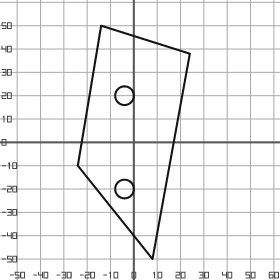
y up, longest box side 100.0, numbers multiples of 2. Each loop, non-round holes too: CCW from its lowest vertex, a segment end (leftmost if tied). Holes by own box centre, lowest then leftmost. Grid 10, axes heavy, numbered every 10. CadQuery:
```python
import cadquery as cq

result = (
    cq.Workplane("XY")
    .moveTo(8.0, -50.0)
    .lineTo(24.0, 38.0)
    .lineTo(-14.0, 50.0)
    .lineTo(-24.0, -10.0)
    .close()
    .moveTo(-4.0, -20.0)
    .circle(4.0)
    .moveTo(-4.0, 20.0)
    .circle(4.0)
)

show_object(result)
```